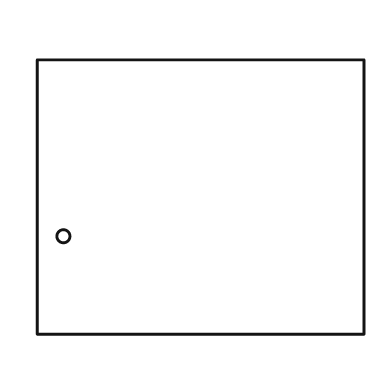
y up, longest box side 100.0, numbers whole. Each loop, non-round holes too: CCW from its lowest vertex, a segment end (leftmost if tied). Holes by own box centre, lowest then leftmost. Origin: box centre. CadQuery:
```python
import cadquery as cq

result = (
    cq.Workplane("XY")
    .moveTo(-50.0, -42.0)
    .lineTo(50.0, -42.0)
    .lineTo(50.0, 42.0)
    .lineTo(-50.0, 42.0)
    .close()
    .moveTo(-42.0, -12.0)
    .circle(2.0)
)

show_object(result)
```